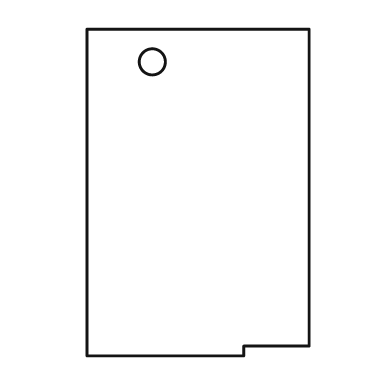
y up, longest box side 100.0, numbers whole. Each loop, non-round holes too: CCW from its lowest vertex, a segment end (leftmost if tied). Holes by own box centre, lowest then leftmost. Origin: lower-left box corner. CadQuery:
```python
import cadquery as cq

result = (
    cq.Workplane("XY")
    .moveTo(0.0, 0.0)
    .lineTo(48.0, 0.0)
    .lineTo(48.0, 3.0)
    .lineTo(68.0, 3.0)
    .lineTo(68.0, 100.0)
    .lineTo(0.0, 100.0)
    .close()
    .moveTo(20.0, 90.0)
    .circle(4.0)
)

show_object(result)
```